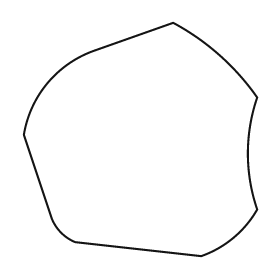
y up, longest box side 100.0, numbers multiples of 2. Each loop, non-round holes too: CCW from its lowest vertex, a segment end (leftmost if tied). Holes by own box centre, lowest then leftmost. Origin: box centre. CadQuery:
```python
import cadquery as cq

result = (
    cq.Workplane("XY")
    .moveTo(26.0, -50.0)
    .threePointArc((40.0, -42.0), (50.0, -30.0))
    .threePointArc((46.0, -6.0), (50.0, 18.0))
    .threePointArc((34.0, 36.0), (14.0, 50.0))
    .lineTo(-20.0, 38.0)
    .threePointArc((-40.0, 24.0), (-50.0, 2.0))
    .lineTo(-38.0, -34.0)
    .threePointArc((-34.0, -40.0), (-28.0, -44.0))
    .close()
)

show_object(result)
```